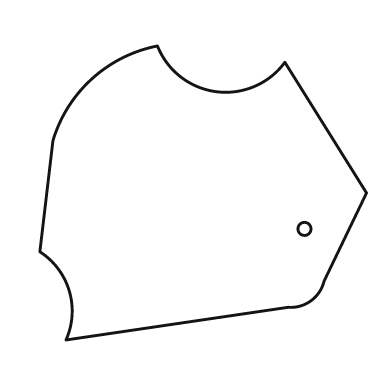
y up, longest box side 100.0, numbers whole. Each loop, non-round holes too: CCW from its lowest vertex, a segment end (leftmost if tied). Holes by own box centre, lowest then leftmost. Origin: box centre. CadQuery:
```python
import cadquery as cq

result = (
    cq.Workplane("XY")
    .moveTo(-42.0, -45.0)
    .lineTo(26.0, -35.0)
    .threePointArc((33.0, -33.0), (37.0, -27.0))
    .lineTo(50.0, 0.0)
    .lineTo(25.0, 40.0)
    .threePointArc((4.0, 31.0), (-14.0, 45.0))
    .threePointArc((-34.0, 35.0), (-46.0, 16.0))
    .lineTo(-50.0, -18.0)
    .threePointArc((-41.0, -30.0), (-42.0, -45.0))
    .close()
    .moveTo(31.0, -11.0)
    .circle(2.0)
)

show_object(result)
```